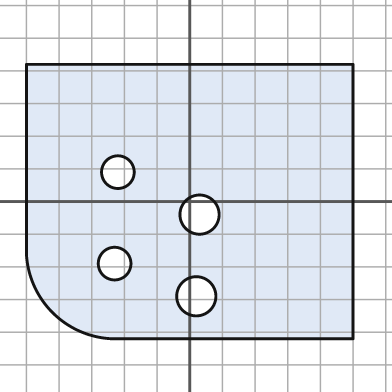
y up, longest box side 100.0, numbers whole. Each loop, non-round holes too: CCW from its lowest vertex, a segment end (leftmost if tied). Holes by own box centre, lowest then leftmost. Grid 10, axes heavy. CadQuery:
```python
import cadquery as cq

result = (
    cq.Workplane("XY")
    .moveTo(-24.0, -42.0)
    .lineTo(50.0, -42.0)
    .lineTo(50.0, 42.0)
    .lineTo(-50.0, 42.0)
    .lineTo(-50.0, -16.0)
    .threePointArc((-42.0, -34.0), (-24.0, -42.0))
    .close()
    .moveTo(2.0, -29.0)
    .circle(6.0)
    .moveTo(-23.0, -19.0)
    .circle(5.0)
    .moveTo(3.0, -4.0)
    .circle(6.0)
    .moveTo(-22.0, 9.0)
    .circle(5.0)
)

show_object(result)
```